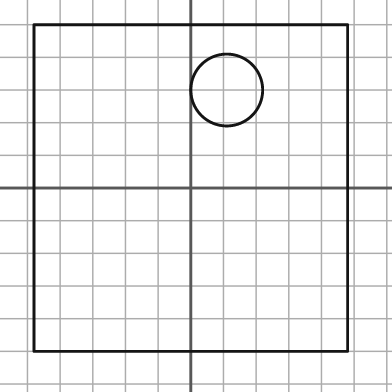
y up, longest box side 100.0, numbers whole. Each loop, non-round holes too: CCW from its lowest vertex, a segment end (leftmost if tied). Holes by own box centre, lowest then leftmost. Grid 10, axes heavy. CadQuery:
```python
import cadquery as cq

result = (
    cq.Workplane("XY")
    .moveTo(-48.0, -50.0)
    .lineTo(48.0, -50.0)
    .lineTo(48.0, 50.0)
    .lineTo(-48.0, 50.0)
    .close()
    .moveTo(11.0, 30.0)
    .circle(11.0)
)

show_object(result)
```